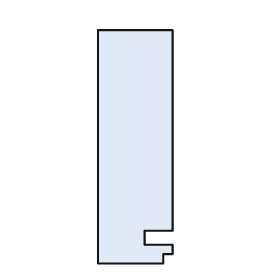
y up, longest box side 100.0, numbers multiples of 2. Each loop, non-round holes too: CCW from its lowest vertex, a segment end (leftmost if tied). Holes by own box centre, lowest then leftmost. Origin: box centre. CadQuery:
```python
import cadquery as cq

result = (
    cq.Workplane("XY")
    .moveTo(-16.0, -50.0)
    .lineTo(12.0, -50.0)
    .lineTo(12.0, -46.0)
    .lineTo(16.0, -46.0)
    .lineTo(16.0, -42.0)
    .lineTo(4.0, -42.0)
    .lineTo(4.0, -36.0)
    .lineTo(16.0, -36.0)
    .lineTo(16.0, 50.0)
    .lineTo(-16.0, 50.0)
    .close()
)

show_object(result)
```